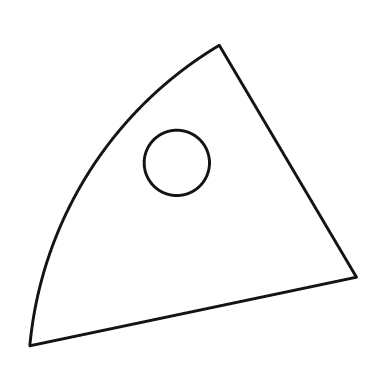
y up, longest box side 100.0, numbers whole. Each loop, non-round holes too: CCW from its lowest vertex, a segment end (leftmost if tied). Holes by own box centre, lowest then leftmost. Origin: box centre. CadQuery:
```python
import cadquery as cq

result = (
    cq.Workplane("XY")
    .moveTo(-50.0, -46.0)
    .lineTo(50.0, -25.0)
    .lineTo(8.0, 46.0)
    .threePointArc((-32.0, 7.0), (-50.0, -46.0))
    .close()
    .moveTo(-5.0, 10.0)
    .circle(10.0)
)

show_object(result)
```